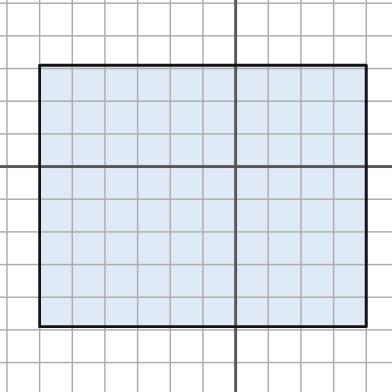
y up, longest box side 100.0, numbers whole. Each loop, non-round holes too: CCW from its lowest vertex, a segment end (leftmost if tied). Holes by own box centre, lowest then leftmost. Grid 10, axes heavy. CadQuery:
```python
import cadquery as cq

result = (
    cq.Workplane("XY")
    .moveTo(-60.0, -49.0)
    .lineTo(40.0, -49.0)
    .lineTo(40.0, 31.0)
    .lineTo(-60.0, 31.0)
    .close()
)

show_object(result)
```